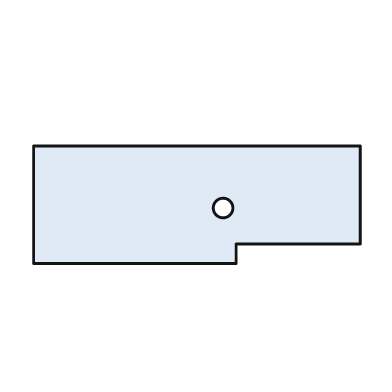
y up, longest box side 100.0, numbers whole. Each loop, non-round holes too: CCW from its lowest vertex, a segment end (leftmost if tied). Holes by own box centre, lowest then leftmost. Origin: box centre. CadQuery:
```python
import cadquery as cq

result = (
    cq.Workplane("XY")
    .moveTo(-50.0, -18.0)
    .lineTo(12.0, -18.0)
    .lineTo(12.0, -12.0)
    .lineTo(50.0, -12.0)
    .lineTo(50.0, 18.0)
    .lineTo(-50.0, 18.0)
    .close()
    .moveTo(8.0, -1.0)
    .circle(3.0)
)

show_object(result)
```